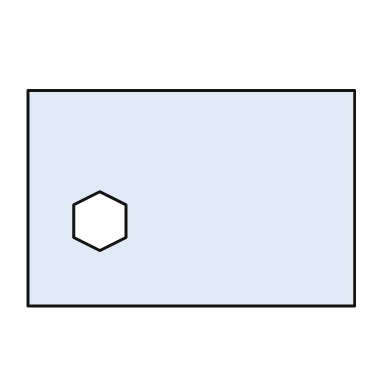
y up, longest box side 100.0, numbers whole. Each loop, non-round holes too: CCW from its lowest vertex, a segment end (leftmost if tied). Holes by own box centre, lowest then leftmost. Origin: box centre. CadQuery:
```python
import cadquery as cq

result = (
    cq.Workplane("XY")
    .moveTo(-50.0, -33.0)
    .lineTo(50.0, -33.0)
    .lineTo(50.0, 33.0)
    .lineTo(-50.0, 33.0)
    .close()
    .moveTo(-28.0, -16.0)
    .lineTo(-20.0, -12.0)
    .lineTo(-20.0, -2.0)
    .lineTo(-28.0, 2.0)
    .lineTo(-36.0, -2.0)
    .lineTo(-36.0, -12.0)
    .close()
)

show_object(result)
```